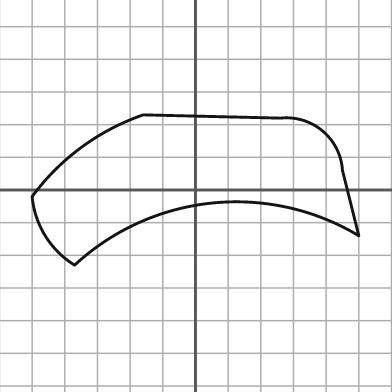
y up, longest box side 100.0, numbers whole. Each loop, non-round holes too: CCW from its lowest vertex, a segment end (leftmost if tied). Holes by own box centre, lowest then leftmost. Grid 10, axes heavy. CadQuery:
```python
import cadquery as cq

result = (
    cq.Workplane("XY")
    .moveTo(-37.0, -23.0)
    .threePointArc((5.0, -4.0), (50.0, -14.0))
    .lineTo(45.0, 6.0)
    .threePointArc((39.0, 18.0), (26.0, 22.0))
    .lineTo(-16.0, 23.0)
    .threePointArc((-35.0, 13.0), (-50.0, -2.0))
    .threePointArc((-46.0, -14.0), (-37.0, -23.0))
    .close()
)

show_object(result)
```